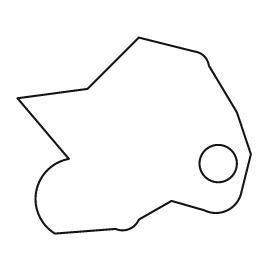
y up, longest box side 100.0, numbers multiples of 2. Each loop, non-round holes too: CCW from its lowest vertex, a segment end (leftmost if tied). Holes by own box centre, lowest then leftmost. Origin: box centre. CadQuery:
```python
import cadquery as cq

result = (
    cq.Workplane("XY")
    .moveTo(-34.0, -42.0)
    .lineTo(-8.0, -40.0)
    .threePointArc((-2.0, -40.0), (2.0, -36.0))
    .lineTo(16.0, -28.0)
    .lineTo(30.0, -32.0)
    .threePointArc((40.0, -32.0), (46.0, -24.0))
    .lineTo(50.0, -8.0)
    .lineTo(44.0, 10.0)
    .lineTo(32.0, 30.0)
    .threePointArc((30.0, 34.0), (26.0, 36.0))
    .lineTo(2.0, 42.0)
    .lineTo(-20.0, 20.0)
    .lineTo(-50.0, 16.0)
    .lineTo(-28.0, -10.0)
    .threePointArc((-42.0, -24.0), (-34.0, -42.0))
    .close()
    .moveTo(36.0, -12.0)
    .circle(8.0)
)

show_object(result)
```